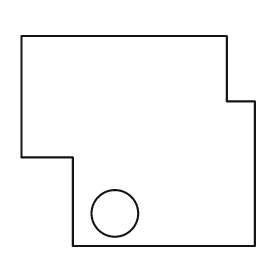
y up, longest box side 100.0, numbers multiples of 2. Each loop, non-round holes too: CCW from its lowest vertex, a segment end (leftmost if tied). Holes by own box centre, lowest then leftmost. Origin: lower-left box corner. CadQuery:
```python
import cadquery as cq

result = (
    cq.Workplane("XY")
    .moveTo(22.0, 0.0)
    .lineTo(100.0, 0.0)
    .lineTo(100.0, 62.0)
    .lineTo(88.0, 62.0)
    .lineTo(88.0, 90.0)
    .lineTo(0.0, 90.0)
    .lineTo(0.0, 38.0)
    .lineTo(22.0, 38.0)
    .close()
    .moveTo(40.0, 14.0)
    .circle(10.0)
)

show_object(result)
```